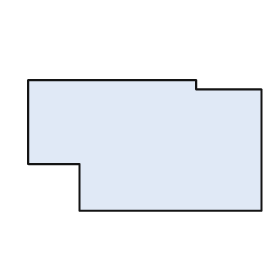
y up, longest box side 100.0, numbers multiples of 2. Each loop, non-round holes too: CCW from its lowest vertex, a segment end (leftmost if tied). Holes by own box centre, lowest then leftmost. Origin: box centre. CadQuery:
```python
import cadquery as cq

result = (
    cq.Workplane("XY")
    .moveTo(-28.0, -28.0)
    .lineTo(50.0, -28.0)
    .lineTo(50.0, 24.0)
    .lineTo(22.0, 24.0)
    .lineTo(22.0, 28.0)
    .lineTo(-50.0, 28.0)
    .lineTo(-50.0, -8.0)
    .lineTo(-28.0, -8.0)
    .close()
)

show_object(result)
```